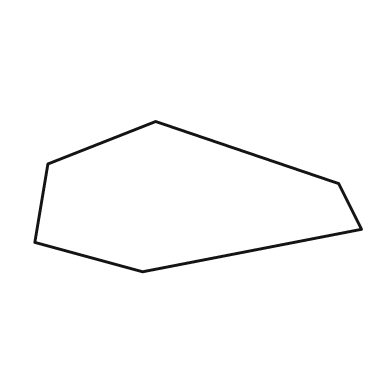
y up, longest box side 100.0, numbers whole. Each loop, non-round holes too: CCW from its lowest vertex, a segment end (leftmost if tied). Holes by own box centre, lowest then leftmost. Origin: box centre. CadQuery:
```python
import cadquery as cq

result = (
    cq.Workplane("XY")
    .moveTo(-17.0, -23.0)
    .lineTo(50.0, -10.0)
    .lineTo(43.0, 4.0)
    .lineTo(-13.0, 23.0)
    .lineTo(-46.0, 10.0)
    .lineTo(-50.0, -14.0)
    .close()
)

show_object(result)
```